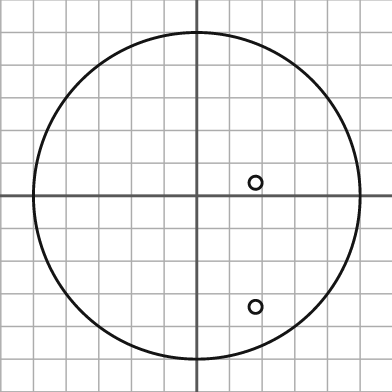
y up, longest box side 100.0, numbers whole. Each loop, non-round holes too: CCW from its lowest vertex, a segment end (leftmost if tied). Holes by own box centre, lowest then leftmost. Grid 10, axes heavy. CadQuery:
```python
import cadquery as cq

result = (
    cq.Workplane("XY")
    .moveTo(0.0, 0.0)
    .circle(50.0)
    .moveTo(18.0, -34.0)
    .circle(2.0)
    .moveTo(18.0, 4.0)
    .circle(2.0)
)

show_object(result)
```